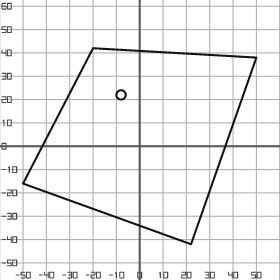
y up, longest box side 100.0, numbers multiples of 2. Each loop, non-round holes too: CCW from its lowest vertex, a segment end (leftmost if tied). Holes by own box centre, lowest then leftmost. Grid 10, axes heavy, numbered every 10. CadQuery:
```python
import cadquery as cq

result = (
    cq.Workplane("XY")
    .moveTo(22.0, -42.0)
    .lineTo(50.0, 38.0)
    .lineTo(-20.0, 42.0)
    .lineTo(-50.0, -16.0)
    .close()
    .moveTo(-8.0, 22.0)
    .circle(2.0)
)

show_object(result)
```